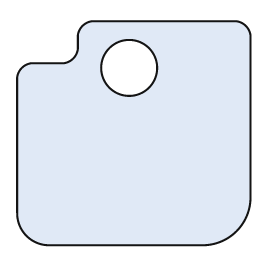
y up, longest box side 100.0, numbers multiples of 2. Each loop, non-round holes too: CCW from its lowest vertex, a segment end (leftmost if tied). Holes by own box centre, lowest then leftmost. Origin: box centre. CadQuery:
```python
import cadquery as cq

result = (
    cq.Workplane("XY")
    .moveTo(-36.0, -48.0)
    .lineTo(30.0, -48.0)
    .threePointArc((44.0, -42.0), (50.0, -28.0))
    .lineTo(50.0, 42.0)
    .threePointArc((48.0, 46.0), (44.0, 48.0))
    .lineTo(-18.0, 48.0)
    .threePointArc((-22.0, 46.0), (-24.0, 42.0))
    .lineTo(-24.0, 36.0)
    .threePointArc((-26.0, 32.0), (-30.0, 30.0))
    .lineTo(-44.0, 30.0)
    .threePointArc((-48.0, 28.0), (-50.0, 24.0))
    .lineTo(-50.0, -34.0)
    .threePointArc((-46.0, -44.0), (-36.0, -48.0))
    .close()
    .moveTo(-2.0, 28.0)
    .circle(12.0)
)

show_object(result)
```